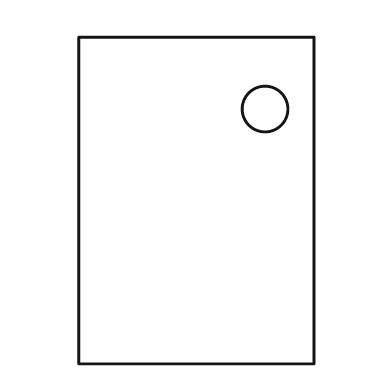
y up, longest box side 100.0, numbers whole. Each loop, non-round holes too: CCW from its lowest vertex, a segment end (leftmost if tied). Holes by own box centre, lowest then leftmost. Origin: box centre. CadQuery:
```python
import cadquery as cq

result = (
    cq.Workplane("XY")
    .moveTo(-36.0, -50.0)
    .lineTo(36.0, -50.0)
    .lineTo(36.0, 50.0)
    .lineTo(-36.0, 50.0)
    .close()
    .moveTo(21.0, 28.0)
    .circle(7.0)
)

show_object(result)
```